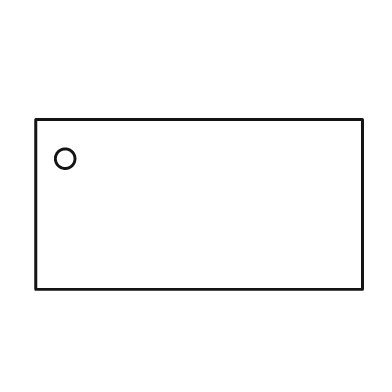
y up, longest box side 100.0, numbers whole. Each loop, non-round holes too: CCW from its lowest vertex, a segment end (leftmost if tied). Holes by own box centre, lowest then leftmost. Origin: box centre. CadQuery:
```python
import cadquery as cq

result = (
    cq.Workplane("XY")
    .moveTo(-50.0, -26.0)
    .lineTo(50.0, -26.0)
    .lineTo(50.0, 26.0)
    .lineTo(-50.0, 26.0)
    .close()
    .moveTo(-41.0, 14.0)
    .circle(3.0)
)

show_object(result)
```